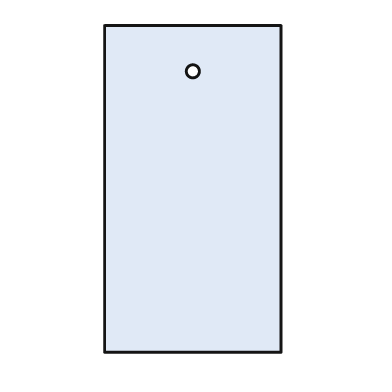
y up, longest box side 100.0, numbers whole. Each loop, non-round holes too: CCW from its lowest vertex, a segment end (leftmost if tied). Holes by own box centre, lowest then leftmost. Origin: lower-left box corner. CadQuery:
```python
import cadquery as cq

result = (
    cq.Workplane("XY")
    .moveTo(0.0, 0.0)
    .lineTo(54.0, 0.0)
    .lineTo(54.0, 100.0)
    .lineTo(0.0, 100.0)
    .close()
    .moveTo(27.0, 86.0)
    .circle(2.0)
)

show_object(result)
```